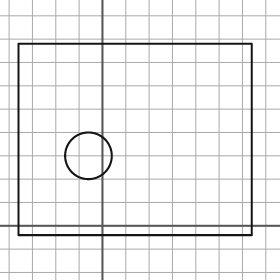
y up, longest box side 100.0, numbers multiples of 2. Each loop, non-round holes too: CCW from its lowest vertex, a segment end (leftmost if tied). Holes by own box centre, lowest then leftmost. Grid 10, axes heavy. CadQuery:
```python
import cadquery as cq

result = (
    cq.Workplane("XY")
    .moveTo(-36.0, -4.0)
    .lineTo(64.0, -4.0)
    .lineTo(64.0, 78.0)
    .lineTo(-36.0, 78.0)
    .close()
    .moveTo(-6.0, 30.0)
    .circle(10.0)
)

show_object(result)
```